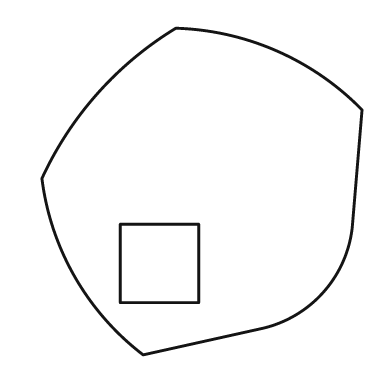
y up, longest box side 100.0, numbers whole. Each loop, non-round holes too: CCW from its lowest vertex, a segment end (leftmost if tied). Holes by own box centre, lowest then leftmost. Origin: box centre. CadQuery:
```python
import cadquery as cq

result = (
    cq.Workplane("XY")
    .moveTo(-18.0, -50.0)
    .lineTo(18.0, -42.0)
    .threePointArc((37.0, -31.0), (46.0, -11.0))
    .lineTo(49.0, 25.0)
    .threePointArc((23.0, 43.0), (-8.0, 50.0))
    .threePointArc((-32.0, 30.0), (-49.0, 4.0))
    .threePointArc((-39.0, -26.0), (-18.0, -50.0))
    .close()
    .moveTo(-25.0, -34.0)
    .lineTo(-1.0, -34.0)
    .lineTo(-1.0, -10.0)
    .lineTo(-25.0, -10.0)
    .close()
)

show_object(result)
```